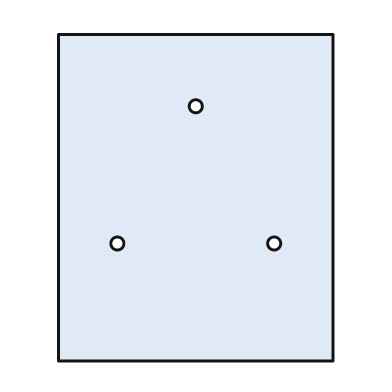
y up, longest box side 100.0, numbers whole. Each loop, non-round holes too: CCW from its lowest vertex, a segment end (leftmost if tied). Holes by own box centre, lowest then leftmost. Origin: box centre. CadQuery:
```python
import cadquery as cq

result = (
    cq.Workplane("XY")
    .moveTo(-42.0, -50.0)
    .lineTo(42.0, -50.0)
    .lineTo(42.0, 50.0)
    .lineTo(-42.0, 50.0)
    .close()
    .moveTo(-24.0, -14.0)
    .circle(2.0)
    .moveTo(24.0, -14.0)
    .circle(2.0)
    .moveTo(0.0, 28.0)
    .circle(2.0)
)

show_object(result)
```